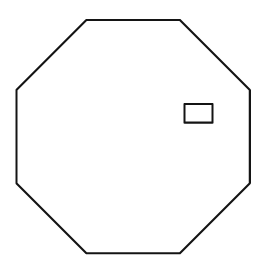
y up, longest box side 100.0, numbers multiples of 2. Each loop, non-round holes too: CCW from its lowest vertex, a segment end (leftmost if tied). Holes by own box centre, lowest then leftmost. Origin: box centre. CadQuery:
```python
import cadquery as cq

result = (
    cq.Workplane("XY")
    .moveTo(-20.0, -50.0)
    .lineTo(20.0, -50.0)
    .lineTo(50.0, -20.0)
    .lineTo(50.0, 20.0)
    .lineTo(20.0, 50.0)
    .lineTo(-20.0, 50.0)
    .lineTo(-50.0, 20.0)
    .lineTo(-50.0, -20.0)
    .close()
    .moveTo(22.0, 6.0)
    .lineTo(34.0, 6.0)
    .lineTo(34.0, 14.0)
    .lineTo(22.0, 14.0)
    .close()
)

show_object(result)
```